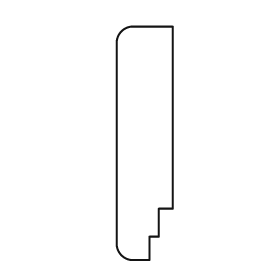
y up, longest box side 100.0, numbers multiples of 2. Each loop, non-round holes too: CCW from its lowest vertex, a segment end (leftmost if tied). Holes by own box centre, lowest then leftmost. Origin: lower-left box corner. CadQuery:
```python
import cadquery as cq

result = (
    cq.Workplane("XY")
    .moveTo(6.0, 0.0)
    .lineTo(14.0, 0.0)
    .lineTo(14.0, 10.0)
    .lineTo(18.0, 10.0)
    .lineTo(18.0, 22.0)
    .lineTo(24.0, 22.0)
    .lineTo(24.0, 100.0)
    .lineTo(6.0, 100.0)
    .threePointArc((2.0, 98.0), (0.0, 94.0))
    .lineTo(0.0, 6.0)
    .threePointArc((2.0, 2.0), (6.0, 0.0))
    .close()
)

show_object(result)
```